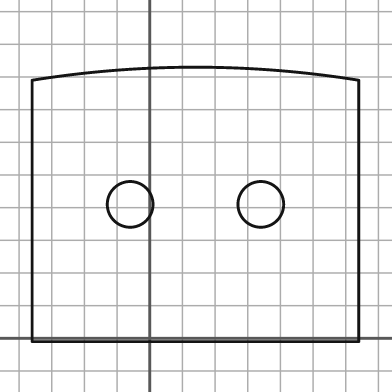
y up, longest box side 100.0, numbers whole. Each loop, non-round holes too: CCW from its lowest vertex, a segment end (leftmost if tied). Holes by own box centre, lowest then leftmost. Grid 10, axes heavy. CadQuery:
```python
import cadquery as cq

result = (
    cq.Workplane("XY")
    .moveTo(-36.0, -1.0)
    .lineTo(64.0, -1.0)
    .lineTo(64.0, 79.0)
    .threePointArc((14.0, 83.0), (-36.0, 79.0))
    .close()
    .moveTo(-6.0, 41.0)
    .circle(7.0)
    .moveTo(34.0, 41.0)
    .circle(7.0)
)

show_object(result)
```